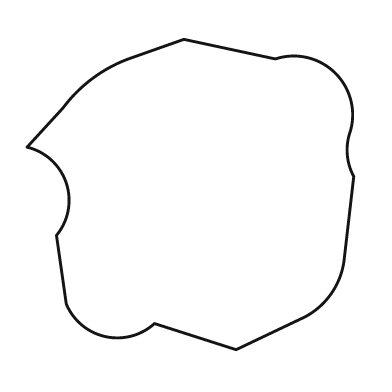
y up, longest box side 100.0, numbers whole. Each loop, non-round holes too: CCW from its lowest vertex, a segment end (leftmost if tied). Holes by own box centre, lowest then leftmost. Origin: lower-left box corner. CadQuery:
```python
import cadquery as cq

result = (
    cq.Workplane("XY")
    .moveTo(64.0, 0.0)
    .lineTo(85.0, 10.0)
    .threePointArc((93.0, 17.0), (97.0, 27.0))
    .lineTo(100.0, 53.0)
    .threePointArc((98.0, 60.0), (99.0, 67.0))
    .threePointArc((94.0, 85.0), (76.0, 89.0))
    .lineTo(48.0, 95.0)
    .lineTo(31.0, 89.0)
    .threePointArc((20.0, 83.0), (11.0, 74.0))
    .lineTo(0.0, 62.0)
    .threePointArc((12.0, 51.0), (9.0, 35.0))
    .lineTo(12.0, 14.0)
    .threePointArc((24.0, 4.0), (39.0, 8.0))
    .close()
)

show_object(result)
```